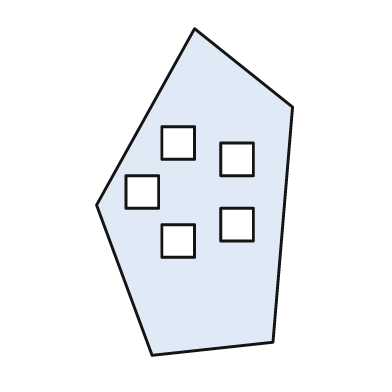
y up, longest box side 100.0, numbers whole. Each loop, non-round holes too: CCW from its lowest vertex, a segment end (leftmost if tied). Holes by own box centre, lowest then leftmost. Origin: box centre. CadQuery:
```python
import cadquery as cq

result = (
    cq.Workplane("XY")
    .moveTo(-13.0, -50.0)
    .lineTo(24.0, -46.0)
    .lineTo(30.0, 26.0)
    .lineTo(0.0, 50.0)
    .lineTo(-30.0, -4.0)
    .close()
    .moveTo(-10.0, -20.0)
    .lineTo(0.0, -20.0)
    .lineTo(0.0, -10.0)
    .lineTo(-10.0, -10.0)
    .close()
    .moveTo(8.0, -15.0)
    .lineTo(18.0, -15.0)
    .lineTo(18.0, -5.0)
    .lineTo(8.0, -5.0)
    .close()
    .moveTo(-21.0, -5.0)
    .lineTo(-11.0, -5.0)
    .lineTo(-11.0, 5.0)
    .lineTo(-21.0, 5.0)
    .close()
    .moveTo(8.0, 5.0)
    .lineTo(18.0, 5.0)
    .lineTo(18.0, 15.0)
    .lineTo(8.0, 15.0)
    .close()
    .moveTo(-10.0, 10.0)
    .lineTo(0.0, 10.0)
    .lineTo(0.0, 20.0)
    .lineTo(-10.0, 20.0)
    .close()
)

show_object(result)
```